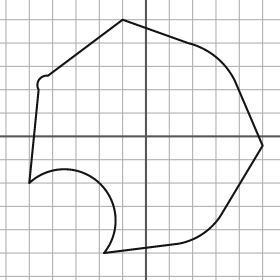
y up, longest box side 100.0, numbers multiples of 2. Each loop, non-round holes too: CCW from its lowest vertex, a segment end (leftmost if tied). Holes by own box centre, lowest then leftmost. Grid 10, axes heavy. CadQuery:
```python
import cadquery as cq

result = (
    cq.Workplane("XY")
    .moveTo(-18.0, -50.0)
    .lineTo(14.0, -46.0)
    .threePointArc((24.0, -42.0), (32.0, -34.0))
    .lineTo(50.0, -4.0)
    .lineTo(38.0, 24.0)
    .threePointArc((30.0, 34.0), (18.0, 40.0))
    .lineTo(-10.0, 50.0)
    .lineTo(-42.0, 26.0)
    .threePointArc((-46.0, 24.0), (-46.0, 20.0))
    .lineTo(-50.0, -20.0)
    .threePointArc((-20.0, -20.0), (-18.0, -50.0))
    .close()
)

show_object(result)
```